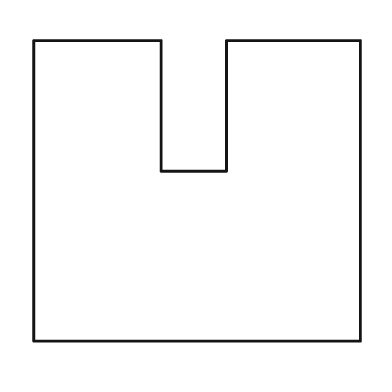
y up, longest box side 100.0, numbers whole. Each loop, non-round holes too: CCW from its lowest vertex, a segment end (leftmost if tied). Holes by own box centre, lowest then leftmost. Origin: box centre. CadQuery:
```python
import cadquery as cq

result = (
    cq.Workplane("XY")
    .moveTo(-50.0, -46.0)
    .lineTo(50.0, -46.0)
    .lineTo(50.0, 46.0)
    .lineTo(9.0, 46.0)
    .lineTo(9.0, 6.0)
    .lineTo(-11.0, 6.0)
    .lineTo(-11.0, 46.0)
    .lineTo(-50.0, 46.0)
    .close()
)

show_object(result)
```